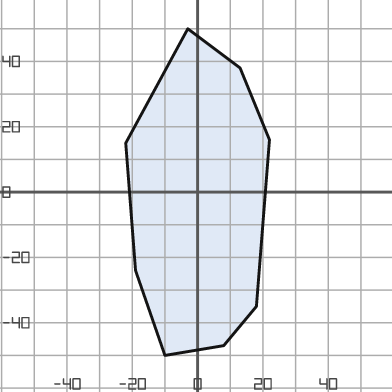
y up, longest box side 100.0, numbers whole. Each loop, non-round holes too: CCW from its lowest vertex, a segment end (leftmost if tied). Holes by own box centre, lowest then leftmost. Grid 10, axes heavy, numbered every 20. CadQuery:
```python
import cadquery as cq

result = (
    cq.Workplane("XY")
    .moveTo(-10.0, -50.0)
    .lineTo(8.0, -47.0)
    .lineTo(18.0, -35.0)
    .lineTo(22.0, 16.0)
    .lineTo(13.0, 38.0)
    .lineTo(-3.0, 50.0)
    .lineTo(-22.0, 15.0)
    .lineTo(-19.0, -24.0)
    .close()
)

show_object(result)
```